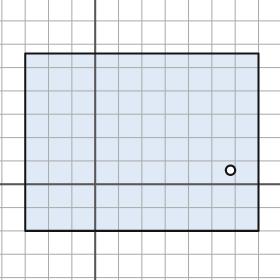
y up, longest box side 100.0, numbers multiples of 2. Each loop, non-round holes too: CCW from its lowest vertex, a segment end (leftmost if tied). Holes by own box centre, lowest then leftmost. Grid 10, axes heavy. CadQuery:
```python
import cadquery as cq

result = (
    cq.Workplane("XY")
    .moveTo(-30.0, -20.0)
    .lineTo(70.0, -20.0)
    .lineTo(70.0, 56.0)
    .lineTo(-30.0, 56.0)
    .close()
    .moveTo(58.0, 6.0)
    .circle(2.0)
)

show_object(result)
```